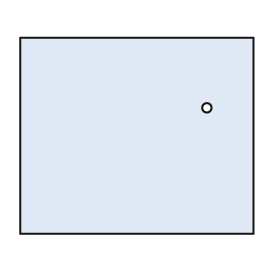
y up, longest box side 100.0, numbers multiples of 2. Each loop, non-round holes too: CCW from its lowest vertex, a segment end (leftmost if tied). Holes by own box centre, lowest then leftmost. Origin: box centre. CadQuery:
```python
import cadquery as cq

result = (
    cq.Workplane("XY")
    .moveTo(-50.0, -42.0)
    .lineTo(50.0, -42.0)
    .lineTo(50.0, 42.0)
    .lineTo(-50.0, 42.0)
    .close()
    .moveTo(30.0, 12.0)
    .circle(2.0)
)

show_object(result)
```